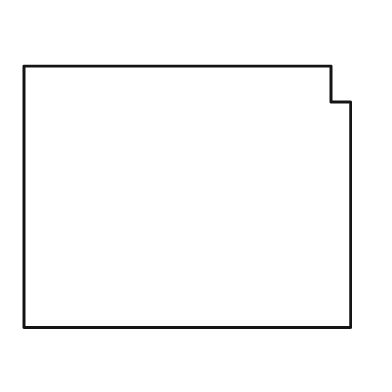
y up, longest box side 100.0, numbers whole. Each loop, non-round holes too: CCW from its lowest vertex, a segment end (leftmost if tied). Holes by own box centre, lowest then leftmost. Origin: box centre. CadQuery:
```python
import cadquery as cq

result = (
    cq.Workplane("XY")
    .moveTo(-50.0, -40.0)
    .lineTo(50.0, -40.0)
    .lineTo(50.0, 29.0)
    .lineTo(44.0, 29.0)
    .lineTo(44.0, 40.0)
    .lineTo(-50.0, 40.0)
    .close()
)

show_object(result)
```